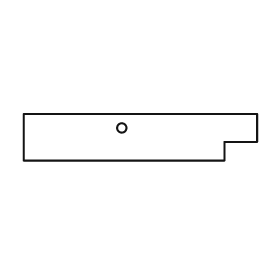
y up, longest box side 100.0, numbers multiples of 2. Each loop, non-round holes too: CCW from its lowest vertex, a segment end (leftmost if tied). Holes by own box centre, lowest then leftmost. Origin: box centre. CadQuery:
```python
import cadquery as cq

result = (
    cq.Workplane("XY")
    .moveTo(-50.0, -10.0)
    .lineTo(36.0, -10.0)
    .lineTo(36.0, -2.0)
    .lineTo(50.0, -2.0)
    .lineTo(50.0, 10.0)
    .lineTo(-50.0, 10.0)
    .close()
    .moveTo(-8.0, 4.0)
    .circle(2.0)
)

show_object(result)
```